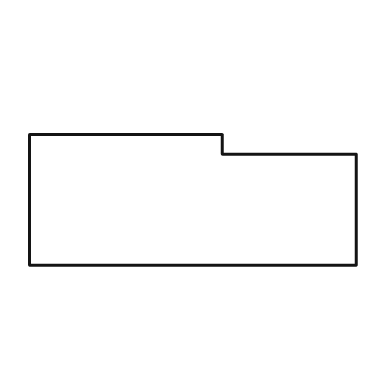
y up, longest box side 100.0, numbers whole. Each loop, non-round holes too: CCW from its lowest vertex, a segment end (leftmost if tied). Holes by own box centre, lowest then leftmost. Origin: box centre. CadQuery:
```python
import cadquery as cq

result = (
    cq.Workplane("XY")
    .moveTo(-50.0, -20.0)
    .lineTo(50.0, -20.0)
    .lineTo(50.0, 14.0)
    .lineTo(9.0, 14.0)
    .lineTo(9.0, 20.0)
    .lineTo(-50.0, 20.0)
    .close()
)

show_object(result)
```